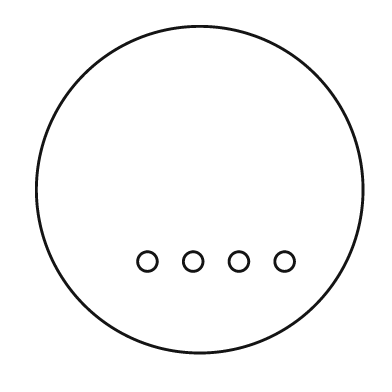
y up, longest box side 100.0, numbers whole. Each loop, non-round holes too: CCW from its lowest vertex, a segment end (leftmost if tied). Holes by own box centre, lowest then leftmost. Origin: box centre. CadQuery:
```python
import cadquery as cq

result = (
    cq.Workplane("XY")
    .moveTo(0.0, 0.0)
    .circle(50.0)
    .moveTo(-16.0, -22.0)
    .circle(3.0)
    .moveTo(-2.0, -22.0)
    .circle(3.0)
    .moveTo(12.0, -22.0)
    .circle(3.0)
    .moveTo(26.0, -22.0)
    .circle(3.0)
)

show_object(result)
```